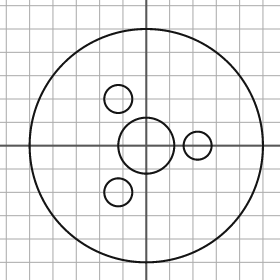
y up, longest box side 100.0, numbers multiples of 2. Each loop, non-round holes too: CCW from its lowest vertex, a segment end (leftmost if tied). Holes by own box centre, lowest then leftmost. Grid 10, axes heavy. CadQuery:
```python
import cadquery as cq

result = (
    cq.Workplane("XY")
    .moveTo(0.0, 0.0)
    .circle(50.0)
    .moveTo(-12.0, -20.0)
    .circle(6.0)
    .moveTo(0.0, 0.0)
    .circle(12.0)
    .moveTo(22.0, 0.0)
    .circle(6.0)
    .moveTo(-12.0, 20.0)
    .circle(6.0)
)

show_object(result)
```